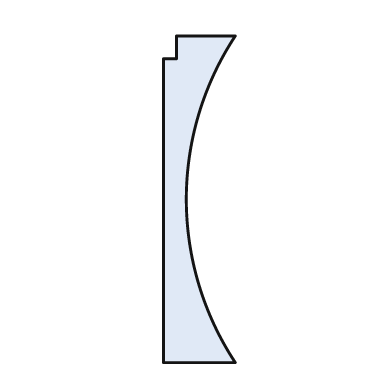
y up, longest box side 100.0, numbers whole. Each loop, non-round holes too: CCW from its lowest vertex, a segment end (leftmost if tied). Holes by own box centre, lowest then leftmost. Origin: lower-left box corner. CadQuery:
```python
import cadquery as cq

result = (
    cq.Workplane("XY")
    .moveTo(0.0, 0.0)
    .lineTo(22.0, 0.0)
    .threePointArc((7.0, 50.0), (22.0, 100.0))
    .lineTo(4.0, 100.0)
    .lineTo(4.0, 93.0)
    .lineTo(0.0, 93.0)
    .close()
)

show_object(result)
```